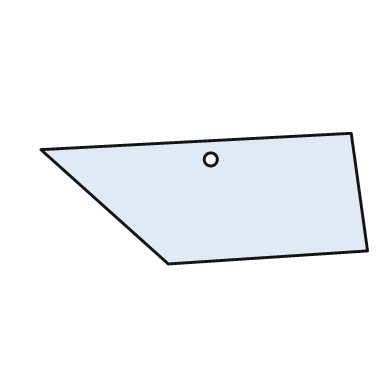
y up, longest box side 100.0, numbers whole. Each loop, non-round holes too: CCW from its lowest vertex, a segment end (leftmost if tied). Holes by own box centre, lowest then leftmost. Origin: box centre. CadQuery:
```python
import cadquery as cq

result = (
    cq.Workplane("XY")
    .moveTo(-11.0, -20.0)
    .lineTo(50.0, -16.0)
    .lineTo(45.0, 20.0)
    .lineTo(-50.0, 15.0)
    .close()
    .moveTo(2.0, 12.0)
    .circle(2.0)
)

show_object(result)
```